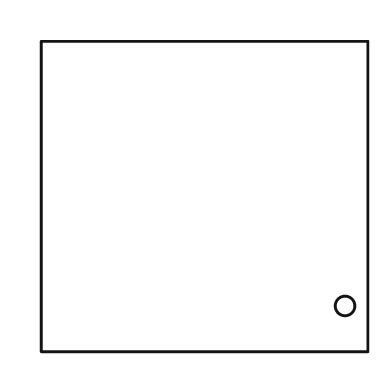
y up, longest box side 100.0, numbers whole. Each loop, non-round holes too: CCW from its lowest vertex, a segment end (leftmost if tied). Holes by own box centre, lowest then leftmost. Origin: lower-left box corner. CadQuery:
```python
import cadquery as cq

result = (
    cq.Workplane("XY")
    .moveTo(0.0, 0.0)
    .lineTo(100.0, 0.0)
    .lineTo(100.0, 95.0)
    .lineTo(0.0, 95.0)
    .close()
    .moveTo(93.0, 14.0)
    .circle(3.0)
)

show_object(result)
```